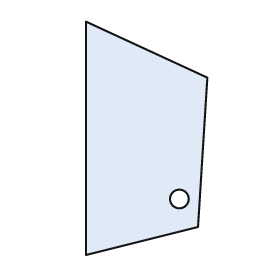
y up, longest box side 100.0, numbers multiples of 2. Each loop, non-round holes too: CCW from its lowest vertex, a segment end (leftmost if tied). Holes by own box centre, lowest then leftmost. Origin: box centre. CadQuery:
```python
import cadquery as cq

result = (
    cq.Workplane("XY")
    .moveTo(-26.0, -50.0)
    .lineTo(22.0, -38.0)
    .lineTo(26.0, 26.0)
    .lineTo(-26.0, 50.0)
    .close()
    .moveTo(14.0, -26.0)
    .circle(4.0)
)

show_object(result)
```